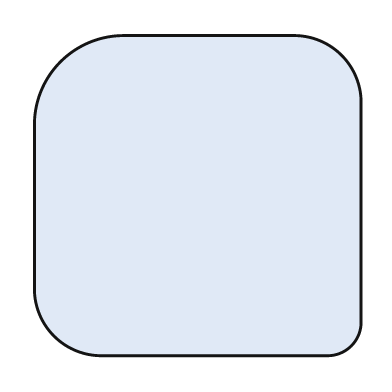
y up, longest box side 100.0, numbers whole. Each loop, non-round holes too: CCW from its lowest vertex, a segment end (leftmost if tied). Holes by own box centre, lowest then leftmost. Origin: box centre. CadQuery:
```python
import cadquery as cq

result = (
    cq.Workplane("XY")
    .moveTo(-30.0, -49.0)
    .lineTo(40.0, -49.0)
    .threePointArc((47.0, -46.0), (50.0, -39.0))
    .lineTo(50.0, 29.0)
    .threePointArc((44.0, 43.0), (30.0, 49.0))
    .lineTo(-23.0, 49.0)
    .threePointArc((-42.0, 41.0), (-50.0, 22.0))
    .lineTo(-50.0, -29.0)
    .threePointArc((-44.0, -43.0), (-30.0, -49.0))
    .close()
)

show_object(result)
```